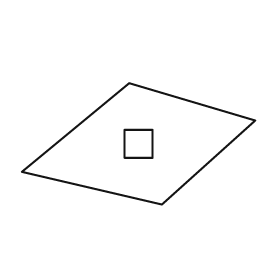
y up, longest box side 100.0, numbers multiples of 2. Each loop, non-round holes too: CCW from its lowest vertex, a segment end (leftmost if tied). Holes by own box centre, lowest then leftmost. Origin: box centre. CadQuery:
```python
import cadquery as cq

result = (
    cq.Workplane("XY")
    .moveTo(10.0, -26.0)
    .lineTo(50.0, 10.0)
    .lineTo(-4.0, 26.0)
    .lineTo(-50.0, -12.0)
    .close()
    .moveTo(-6.0, -6.0)
    .lineTo(6.0, -6.0)
    .lineTo(6.0, 6.0)
    .lineTo(-6.0, 6.0)
    .close()
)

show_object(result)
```